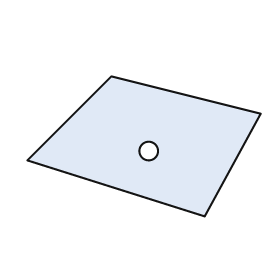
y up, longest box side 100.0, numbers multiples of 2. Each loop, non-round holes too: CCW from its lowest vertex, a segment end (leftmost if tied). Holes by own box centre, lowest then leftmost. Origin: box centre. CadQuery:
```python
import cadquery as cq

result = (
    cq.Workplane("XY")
    .moveTo(26.0, -30.0)
    .lineTo(50.0, 14.0)
    .lineTo(-14.0, 30.0)
    .lineTo(-50.0, -6.0)
    .close()
    .moveTo(2.0, -2.0)
    .circle(4.0)
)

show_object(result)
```